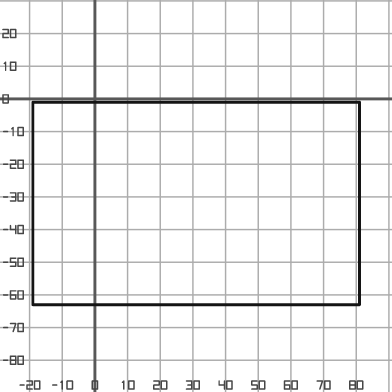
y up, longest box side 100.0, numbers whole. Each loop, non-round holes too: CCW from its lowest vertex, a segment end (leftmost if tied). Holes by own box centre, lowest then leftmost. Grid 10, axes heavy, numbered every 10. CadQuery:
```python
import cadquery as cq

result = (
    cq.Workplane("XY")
    .moveTo(-19.0, -63.0)
    .lineTo(81.0, -63.0)
    .lineTo(81.0, -1.0)
    .lineTo(-19.0, -1.0)
    .close()
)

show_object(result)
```